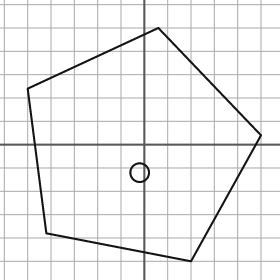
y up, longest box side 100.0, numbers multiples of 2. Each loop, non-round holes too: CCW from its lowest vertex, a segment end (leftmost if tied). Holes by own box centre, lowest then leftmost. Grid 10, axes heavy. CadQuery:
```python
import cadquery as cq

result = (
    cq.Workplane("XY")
    .moveTo(20.0, -50.0)
    .lineTo(50.0, 4.0)
    .lineTo(6.0, 50.0)
    .lineTo(-50.0, 24.0)
    .lineTo(-42.0, -38.0)
    .close()
    .moveTo(-2.0, -12.0)
    .circle(4.0)
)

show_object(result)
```